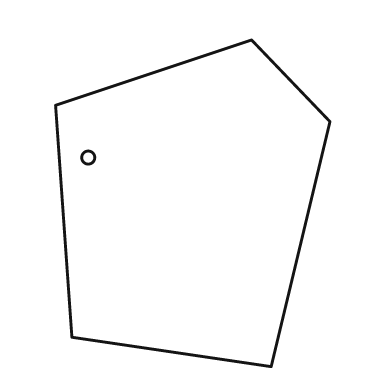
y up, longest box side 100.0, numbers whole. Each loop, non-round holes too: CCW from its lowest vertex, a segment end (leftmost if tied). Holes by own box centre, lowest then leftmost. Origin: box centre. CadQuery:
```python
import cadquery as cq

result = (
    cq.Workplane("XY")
    .moveTo(24.0, -50.0)
    .lineTo(42.0, 25.0)
    .lineTo(18.0, 50.0)
    .lineTo(-42.0, 30.0)
    .lineTo(-37.0, -41.0)
    .close()
    .moveTo(-32.0, 14.0)
    .circle(2.0)
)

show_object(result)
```